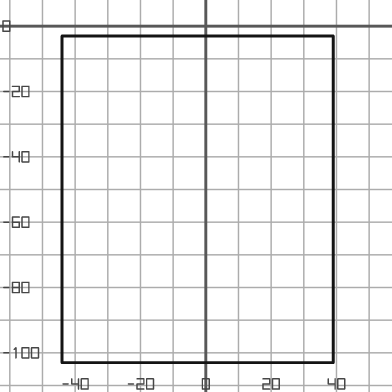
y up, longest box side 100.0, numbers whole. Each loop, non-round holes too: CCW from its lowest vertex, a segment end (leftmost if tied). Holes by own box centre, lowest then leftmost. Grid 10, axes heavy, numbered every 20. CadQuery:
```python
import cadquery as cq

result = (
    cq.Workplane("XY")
    .moveTo(-44.0, -103.0)
    .lineTo(39.0, -103.0)
    .lineTo(39.0, -3.0)
    .lineTo(-44.0, -3.0)
    .close()
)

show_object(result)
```